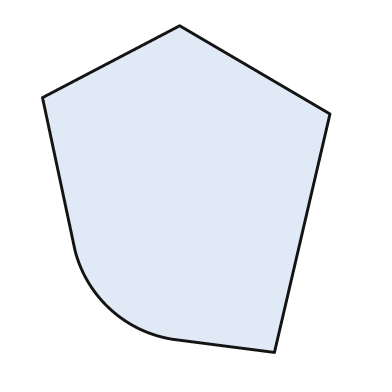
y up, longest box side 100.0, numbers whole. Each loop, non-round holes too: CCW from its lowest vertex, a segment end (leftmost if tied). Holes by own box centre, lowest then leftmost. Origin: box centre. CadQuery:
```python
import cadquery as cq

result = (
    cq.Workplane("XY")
    .moveTo(27.0, -50.0)
    .lineTo(44.0, 23.0)
    .lineTo(-2.0, 50.0)
    .lineTo(-44.0, 28.0)
    .lineTo(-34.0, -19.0)
    .threePointArc((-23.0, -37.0), (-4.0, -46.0))
    .close()
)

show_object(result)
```